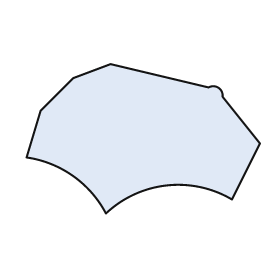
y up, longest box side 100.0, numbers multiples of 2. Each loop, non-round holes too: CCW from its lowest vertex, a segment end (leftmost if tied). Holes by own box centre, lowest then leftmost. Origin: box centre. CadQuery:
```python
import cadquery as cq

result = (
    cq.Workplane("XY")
    .moveTo(-16.0, -32.0)
    .threePointArc((10.0, -20.0), (38.0, -26.0))
    .lineTo(50.0, -2.0)
    .lineTo(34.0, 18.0)
    .threePointArc((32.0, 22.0), (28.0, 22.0))
    .lineTo(-14.0, 32.0)
    .lineTo(-30.0, 26.0)
    .lineTo(-44.0, 12.0)
    .lineTo(-50.0, -8.0)
    .threePointArc((-30.0, -16.0), (-16.0, -32.0))
    .close()
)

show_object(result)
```